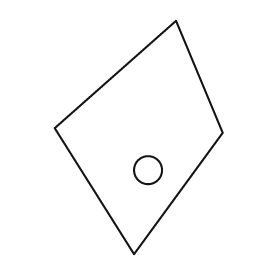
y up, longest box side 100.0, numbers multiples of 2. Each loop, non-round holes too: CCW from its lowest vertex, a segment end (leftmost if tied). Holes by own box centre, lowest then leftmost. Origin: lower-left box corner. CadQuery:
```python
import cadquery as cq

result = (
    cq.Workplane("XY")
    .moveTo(34.0, 0.0)
    .lineTo(72.0, 52.0)
    .lineTo(52.0, 100.0)
    .lineTo(0.0, 54.0)
    .close()
    .moveTo(40.0, 36.0)
    .circle(6.0)
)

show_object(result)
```